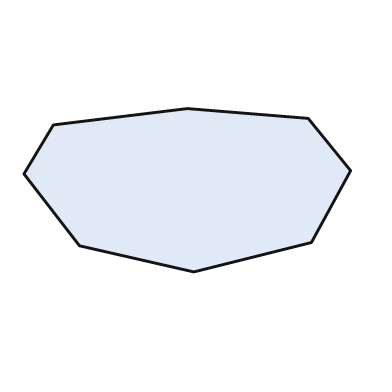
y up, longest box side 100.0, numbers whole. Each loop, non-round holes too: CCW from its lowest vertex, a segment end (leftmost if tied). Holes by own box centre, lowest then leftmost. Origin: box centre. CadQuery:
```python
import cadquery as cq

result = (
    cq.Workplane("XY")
    .moveTo(2.0, -25.0)
    .lineTo(38.0, -16.0)
    .lineTo(50.0, 6.0)
    .lineTo(37.0, 22.0)
    .lineTo(0.0, 25.0)
    .lineTo(-41.0, 20.0)
    .lineTo(-50.0, 5.0)
    .lineTo(-33.0, -17.0)
    .close()
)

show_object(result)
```